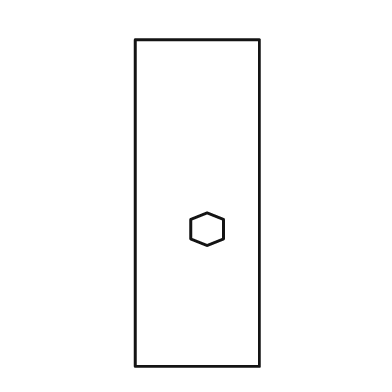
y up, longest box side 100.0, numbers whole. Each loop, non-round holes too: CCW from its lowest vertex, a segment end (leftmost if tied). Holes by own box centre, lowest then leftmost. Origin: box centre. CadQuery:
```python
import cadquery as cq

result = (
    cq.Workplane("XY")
    .moveTo(-19.0, -50.0)
    .lineTo(19.0, -50.0)
    .lineTo(19.0, 50.0)
    .lineTo(-19.0, 50.0)
    .close()
    .moveTo(3.0, -13.0)
    .lineTo(8.0, -11.0)
    .lineTo(8.0, -5.0)
    .lineTo(3.0, -3.0)
    .lineTo(-2.0, -5.0)
    .lineTo(-2.0, -11.0)
    .close()
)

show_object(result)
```